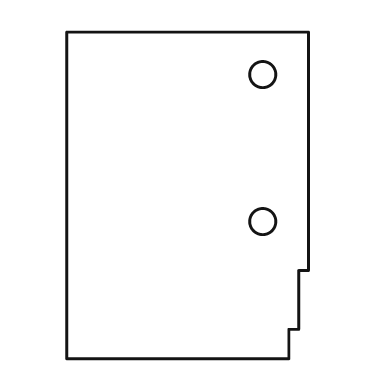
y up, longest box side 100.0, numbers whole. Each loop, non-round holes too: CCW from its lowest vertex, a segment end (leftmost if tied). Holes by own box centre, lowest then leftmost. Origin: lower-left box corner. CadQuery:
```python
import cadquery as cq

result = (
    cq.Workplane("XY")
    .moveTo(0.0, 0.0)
    .lineTo(68.0, 0.0)
    .lineTo(68.0, 9.0)
    .lineTo(71.0, 9.0)
    .lineTo(71.0, 27.0)
    .lineTo(74.0, 27.0)
    .lineTo(74.0, 100.0)
    .lineTo(0.0, 100.0)
    .close()
    .moveTo(60.0, 42.0)
    .circle(4.0)
    .moveTo(60.0, 87.0)
    .circle(4.0)
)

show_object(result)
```